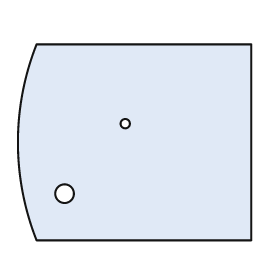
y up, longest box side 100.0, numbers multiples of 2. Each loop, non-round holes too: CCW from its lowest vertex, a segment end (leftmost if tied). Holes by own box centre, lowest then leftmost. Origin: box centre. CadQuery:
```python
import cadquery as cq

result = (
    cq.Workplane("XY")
    .moveTo(-42.0, -42.0)
    .lineTo(50.0, -42.0)
    .lineTo(50.0, 42.0)
    .lineTo(-42.0, 42.0)
    .threePointArc((-50.0, 0.0), (-42.0, -42.0))
    .close()
    .moveTo(-30.0, -22.0)
    .circle(4.0)
    .moveTo(-4.0, 8.0)
    .circle(2.0)
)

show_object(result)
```